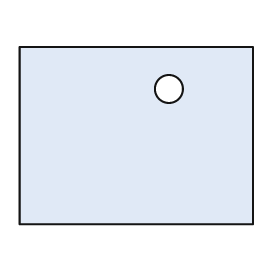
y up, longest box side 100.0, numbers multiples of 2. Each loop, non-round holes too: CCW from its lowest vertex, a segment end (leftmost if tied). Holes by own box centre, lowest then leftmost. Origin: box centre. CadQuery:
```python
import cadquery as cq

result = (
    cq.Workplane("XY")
    .moveTo(-50.0, -38.0)
    .lineTo(50.0, -38.0)
    .lineTo(50.0, 38.0)
    .lineTo(-50.0, 38.0)
    .close()
    .moveTo(14.0, 20.0)
    .circle(6.0)
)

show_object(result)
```